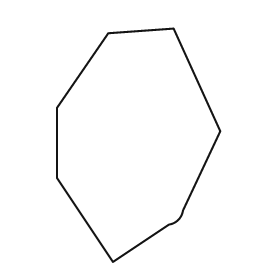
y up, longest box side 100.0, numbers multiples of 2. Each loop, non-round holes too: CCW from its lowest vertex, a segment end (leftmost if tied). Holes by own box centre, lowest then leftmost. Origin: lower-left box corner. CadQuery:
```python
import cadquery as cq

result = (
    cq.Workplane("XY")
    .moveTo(24.0, 0.0)
    .lineTo(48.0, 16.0)
    .threePointArc((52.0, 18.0), (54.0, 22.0))
    .lineTo(70.0, 56.0)
    .lineTo(50.0, 100.0)
    .lineTo(22.0, 98.0)
    .lineTo(0.0, 66.0)
    .lineTo(0.0, 36.0)
    .close()
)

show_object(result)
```